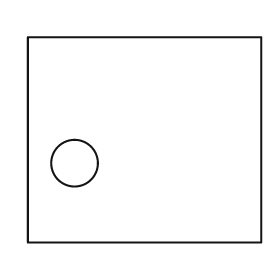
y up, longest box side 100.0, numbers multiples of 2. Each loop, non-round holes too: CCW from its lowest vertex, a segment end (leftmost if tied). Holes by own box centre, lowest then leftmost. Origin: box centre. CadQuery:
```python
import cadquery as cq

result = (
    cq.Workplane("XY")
    .moveTo(-50.0, -44.0)
    .lineTo(50.0, -44.0)
    .lineTo(50.0, 44.0)
    .lineTo(-50.0, 44.0)
    .close()
    .moveTo(-30.0, -10.0)
    .circle(10.0)
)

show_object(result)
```